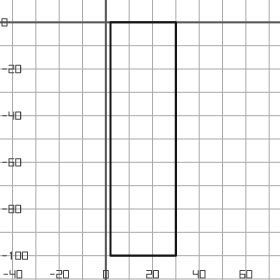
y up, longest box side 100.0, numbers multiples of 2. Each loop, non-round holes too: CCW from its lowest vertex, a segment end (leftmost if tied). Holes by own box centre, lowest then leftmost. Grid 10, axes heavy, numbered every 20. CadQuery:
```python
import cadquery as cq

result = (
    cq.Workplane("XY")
    .moveTo(2.0, -100.0)
    .lineTo(30.0, -100.0)
    .lineTo(30.0, 0.0)
    .lineTo(2.0, 0.0)
    .close()
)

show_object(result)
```